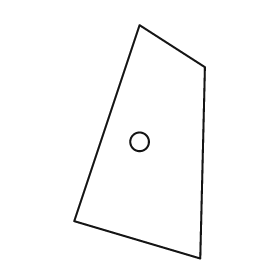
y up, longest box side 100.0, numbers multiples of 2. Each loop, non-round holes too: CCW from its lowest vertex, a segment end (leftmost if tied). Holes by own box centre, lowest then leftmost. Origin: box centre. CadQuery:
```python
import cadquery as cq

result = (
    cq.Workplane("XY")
    .moveTo(26.0, -50.0)
    .lineTo(28.0, 32.0)
    .lineTo(0.0, 50.0)
    .lineTo(-28.0, -34.0)
    .close()
    .moveTo(0.0, 0.0)
    .circle(4.0)
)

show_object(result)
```